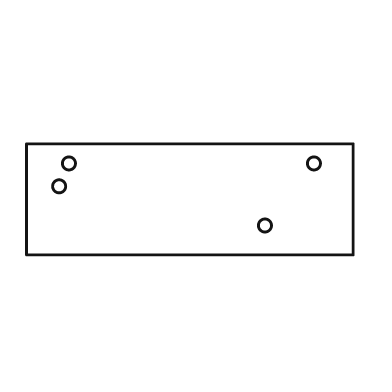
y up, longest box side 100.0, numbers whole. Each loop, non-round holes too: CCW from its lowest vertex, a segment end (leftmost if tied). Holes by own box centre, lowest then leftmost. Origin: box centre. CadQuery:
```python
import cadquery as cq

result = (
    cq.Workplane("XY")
    .moveTo(-50.0, -17.0)
    .lineTo(50.0, -17.0)
    .lineTo(50.0, 17.0)
    .lineTo(-50.0, 17.0)
    .close()
    .moveTo(23.0, -8.0)
    .circle(2.0)
    .moveTo(-40.0, 4.0)
    .circle(2.0)
    .moveTo(-37.0, 11.0)
    .circle(2.0)
    .moveTo(38.0, 11.0)
    .circle(2.0)
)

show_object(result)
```